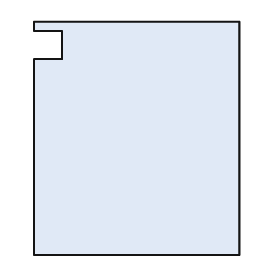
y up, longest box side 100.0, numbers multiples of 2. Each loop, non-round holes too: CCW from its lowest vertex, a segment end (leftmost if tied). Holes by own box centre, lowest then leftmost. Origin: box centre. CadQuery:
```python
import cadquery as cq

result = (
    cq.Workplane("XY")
    .moveTo(-44.0, -50.0)
    .lineTo(44.0, -50.0)
    .lineTo(44.0, 50.0)
    .lineTo(-44.0, 50.0)
    .lineTo(-44.0, 46.0)
    .lineTo(-32.0, 46.0)
    .lineTo(-32.0, 34.0)
    .lineTo(-44.0, 34.0)
    .close()
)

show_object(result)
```